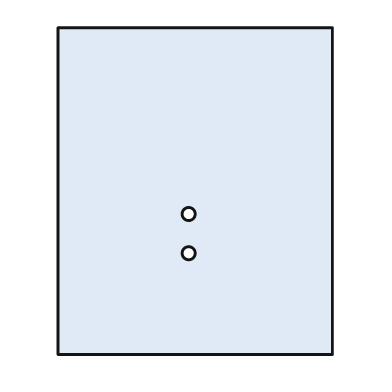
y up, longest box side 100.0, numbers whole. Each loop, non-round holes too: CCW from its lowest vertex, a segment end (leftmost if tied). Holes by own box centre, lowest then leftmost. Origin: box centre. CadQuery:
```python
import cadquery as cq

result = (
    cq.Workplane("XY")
    .moveTo(-42.0, -50.0)
    .lineTo(42.0, -50.0)
    .lineTo(42.0, 50.0)
    .lineTo(-42.0, 50.0)
    .close()
    .moveTo(-2.0, -19.0)
    .circle(2.0)
    .moveTo(-2.0, -7.0)
    .circle(2.0)
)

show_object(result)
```